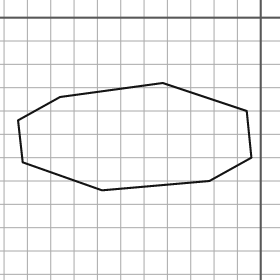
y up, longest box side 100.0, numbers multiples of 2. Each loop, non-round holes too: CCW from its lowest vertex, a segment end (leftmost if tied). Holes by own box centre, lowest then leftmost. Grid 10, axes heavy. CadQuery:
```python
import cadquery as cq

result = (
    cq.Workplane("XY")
    .moveTo(-68.0, -74.0)
    .lineTo(-22.0, -70.0)
    .lineTo(-4.0, -60.0)
    .lineTo(-6.0, -40.0)
    .lineTo(-42.0, -28.0)
    .lineTo(-86.0, -34.0)
    .lineTo(-104.0, -44.0)
    .lineTo(-102.0, -62.0)
    .close()
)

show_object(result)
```